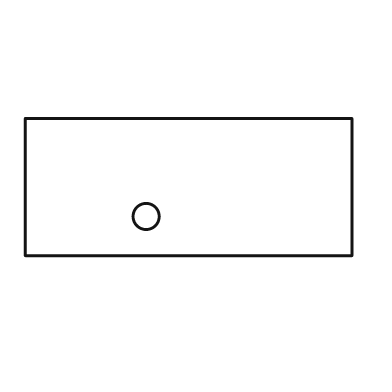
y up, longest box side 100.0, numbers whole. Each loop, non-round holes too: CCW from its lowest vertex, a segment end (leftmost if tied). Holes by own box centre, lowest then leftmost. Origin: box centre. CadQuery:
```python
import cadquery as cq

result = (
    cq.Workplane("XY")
    .moveTo(-50.0, -21.0)
    .lineTo(50.0, -21.0)
    .lineTo(50.0, 21.0)
    .lineTo(-50.0, 21.0)
    .close()
    .moveTo(-13.0, -9.0)
    .circle(4.0)
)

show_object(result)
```